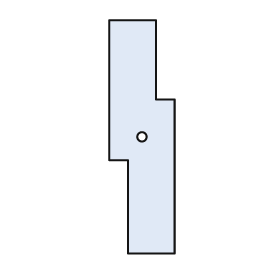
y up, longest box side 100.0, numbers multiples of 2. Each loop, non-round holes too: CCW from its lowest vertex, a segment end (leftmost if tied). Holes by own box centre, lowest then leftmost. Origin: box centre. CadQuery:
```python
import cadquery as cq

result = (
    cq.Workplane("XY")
    .moveTo(-6.0, -50.0)
    .lineTo(14.0, -50.0)
    .lineTo(14.0, 16.0)
    .lineTo(6.0, 16.0)
    .lineTo(6.0, 50.0)
    .lineTo(-14.0, 50.0)
    .lineTo(-14.0, -10.0)
    .lineTo(-6.0, -10.0)
    .close()
    .moveTo(0.0, 0.0)
    .circle(2.0)
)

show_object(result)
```